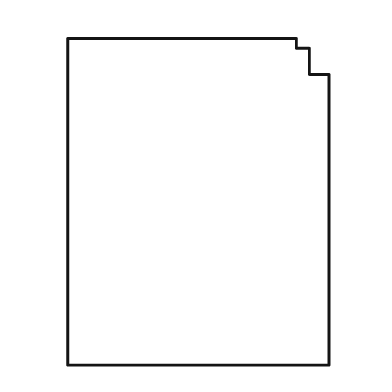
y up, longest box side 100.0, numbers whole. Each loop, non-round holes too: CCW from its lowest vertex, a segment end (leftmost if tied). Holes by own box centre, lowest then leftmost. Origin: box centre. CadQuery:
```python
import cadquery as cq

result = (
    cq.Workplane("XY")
    .moveTo(-40.0, -50.0)
    .lineTo(40.0, -50.0)
    .lineTo(40.0, 39.0)
    .lineTo(34.0, 39.0)
    .lineTo(34.0, 47.0)
    .lineTo(30.0, 47.0)
    .lineTo(30.0, 50.0)
    .lineTo(-40.0, 50.0)
    .close()
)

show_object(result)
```